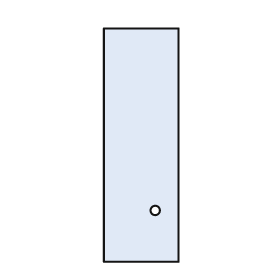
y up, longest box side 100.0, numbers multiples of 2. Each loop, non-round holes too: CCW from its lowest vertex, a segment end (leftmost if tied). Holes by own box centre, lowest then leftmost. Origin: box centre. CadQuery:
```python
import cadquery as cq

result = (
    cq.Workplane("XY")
    .moveTo(-16.0, -50.0)
    .lineTo(16.0, -50.0)
    .lineTo(16.0, 50.0)
    .lineTo(-16.0, 50.0)
    .close()
    .moveTo(6.0, -28.0)
    .circle(2.0)
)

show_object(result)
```